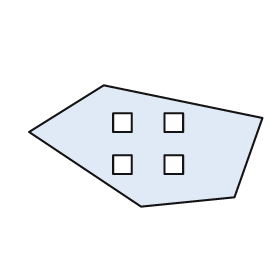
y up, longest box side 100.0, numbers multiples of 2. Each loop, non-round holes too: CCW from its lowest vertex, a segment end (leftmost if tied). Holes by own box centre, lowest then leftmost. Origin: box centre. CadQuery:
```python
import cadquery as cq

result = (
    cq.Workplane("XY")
    .moveTo(-2.0, -26.0)
    .lineTo(38.0, -22.0)
    .lineTo(50.0, 12.0)
    .lineTo(-18.0, 26.0)
    .lineTo(-50.0, 6.0)
    .close()
    .moveTo(-14.0, -12.0)
    .lineTo(-6.0, -12.0)
    .lineTo(-6.0, -4.0)
    .lineTo(-14.0, -4.0)
    .close()
    .moveTo(8.0, -12.0)
    .lineTo(16.0, -12.0)
    .lineTo(16.0, -4.0)
    .lineTo(8.0, -4.0)
    .close()
    .moveTo(-14.0, 6.0)
    .lineTo(-6.0, 6.0)
    .lineTo(-6.0, 14.0)
    .lineTo(-14.0, 14.0)
    .close()
    .moveTo(8.0, 6.0)
    .lineTo(16.0, 6.0)
    .lineTo(16.0, 14.0)
    .lineTo(8.0, 14.0)
    .close()
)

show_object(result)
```